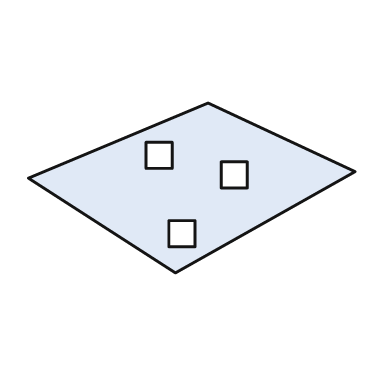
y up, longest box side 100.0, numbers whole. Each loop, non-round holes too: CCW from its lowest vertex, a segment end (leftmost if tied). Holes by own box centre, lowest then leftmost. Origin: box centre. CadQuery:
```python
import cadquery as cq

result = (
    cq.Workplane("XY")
    .moveTo(-5.0, -26.0)
    .lineTo(50.0, 5.0)
    .lineTo(5.0, 26.0)
    .lineTo(-50.0, 3.0)
    .close()
    .moveTo(-7.0, -18.0)
    .lineTo(1.0, -18.0)
    .lineTo(1.0, -10.0)
    .lineTo(-7.0, -10.0)
    .close()
    .moveTo(9.0, 0.0)
    .lineTo(17.0, 0.0)
    .lineTo(17.0, 8.0)
    .lineTo(9.0, 8.0)
    .close()
    .moveTo(-14.0, 6.0)
    .lineTo(-6.0, 6.0)
    .lineTo(-6.0, 14.0)
    .lineTo(-14.0, 14.0)
    .close()
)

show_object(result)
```